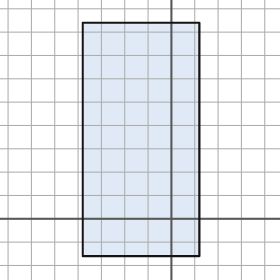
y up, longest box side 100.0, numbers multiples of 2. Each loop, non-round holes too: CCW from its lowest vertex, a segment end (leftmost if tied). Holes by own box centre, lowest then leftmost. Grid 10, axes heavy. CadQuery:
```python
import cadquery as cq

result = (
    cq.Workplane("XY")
    .moveTo(-38.0, -16.0)
    .lineTo(12.0, -16.0)
    .lineTo(12.0, 84.0)
    .lineTo(-38.0, 84.0)
    .close()
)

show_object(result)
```